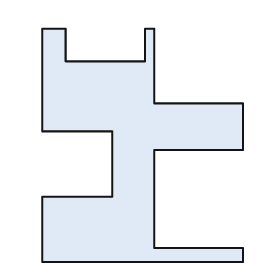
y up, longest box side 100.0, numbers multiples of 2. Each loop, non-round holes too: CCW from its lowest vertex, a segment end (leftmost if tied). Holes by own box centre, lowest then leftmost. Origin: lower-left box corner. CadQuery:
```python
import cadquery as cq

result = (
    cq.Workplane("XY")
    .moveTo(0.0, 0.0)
    .lineTo(86.0, 0.0)
    .lineTo(86.0, 6.0)
    .lineTo(48.0, 6.0)
    .lineTo(48.0, 48.0)
    .lineTo(86.0, 48.0)
    .lineTo(86.0, 68.0)
    .lineTo(48.0, 68.0)
    .lineTo(48.0, 100.0)
    .lineTo(44.0, 100.0)
    .lineTo(44.0, 86.0)
    .lineTo(10.0, 86.0)
    .lineTo(10.0, 100.0)
    .lineTo(0.0, 100.0)
    .lineTo(0.0, 56.0)
    .lineTo(30.0, 56.0)
    .lineTo(30.0, 28.0)
    .lineTo(0.0, 28.0)
    .close()
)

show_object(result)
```